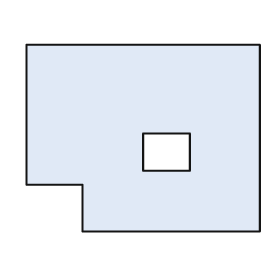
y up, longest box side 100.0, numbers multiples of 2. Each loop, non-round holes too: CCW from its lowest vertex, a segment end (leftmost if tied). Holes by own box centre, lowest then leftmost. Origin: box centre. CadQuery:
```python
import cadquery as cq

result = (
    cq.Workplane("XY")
    .moveTo(-26.0, -40.0)
    .lineTo(50.0, -40.0)
    .lineTo(50.0, 40.0)
    .lineTo(-50.0, 40.0)
    .lineTo(-50.0, -20.0)
    .lineTo(-26.0, -20.0)
    .close()
    .moveTo(0.0, -14.0)
    .lineTo(20.0, -14.0)
    .lineTo(20.0, 2.0)
    .lineTo(0.0, 2.0)
    .close()
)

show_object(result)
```